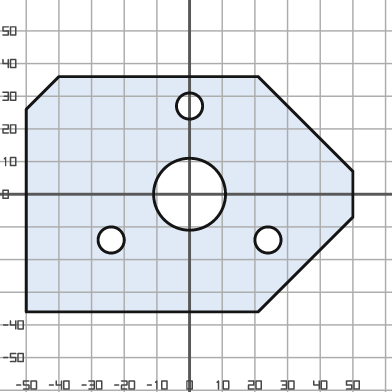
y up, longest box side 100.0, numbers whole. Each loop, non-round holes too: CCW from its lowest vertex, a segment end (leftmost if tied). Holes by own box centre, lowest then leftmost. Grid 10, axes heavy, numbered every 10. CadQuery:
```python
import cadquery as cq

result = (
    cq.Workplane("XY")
    .moveTo(-50.0, -36.0)
    .lineTo(21.0, -36.0)
    .lineTo(50.0, -7.0)
    .lineTo(50.0, 7.0)
    .lineTo(21.0, 36.0)
    .lineTo(-40.0, 36.0)
    .lineTo(-50.0, 26.0)
    .close()
    .moveTo(-24.0, -14.0)
    .circle(4.0)
    .moveTo(24.0, -14.0)
    .circle(4.0)
    .moveTo(0.0, 0.0)
    .circle(11.0)
    .moveTo(0.0, 27.0)
    .circle(4.0)
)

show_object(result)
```